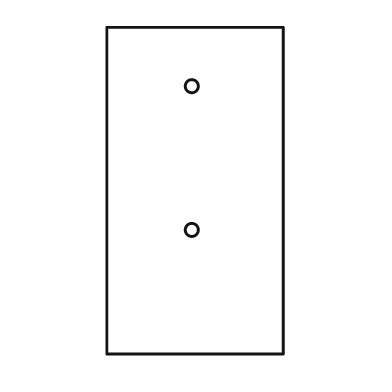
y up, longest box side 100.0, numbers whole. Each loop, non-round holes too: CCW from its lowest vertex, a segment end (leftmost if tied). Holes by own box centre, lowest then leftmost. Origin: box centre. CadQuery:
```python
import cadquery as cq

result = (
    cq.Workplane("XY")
    .moveTo(-27.0, -50.0)
    .lineTo(27.0, -50.0)
    .lineTo(27.0, 50.0)
    .lineTo(-27.0, 50.0)
    .close()
    .moveTo(-1.0, -12.0)
    .circle(2.0)
    .moveTo(-1.0, 32.0)
    .circle(2.0)
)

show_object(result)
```